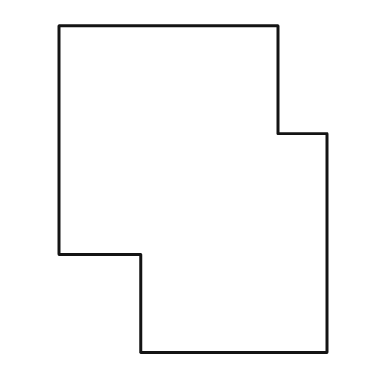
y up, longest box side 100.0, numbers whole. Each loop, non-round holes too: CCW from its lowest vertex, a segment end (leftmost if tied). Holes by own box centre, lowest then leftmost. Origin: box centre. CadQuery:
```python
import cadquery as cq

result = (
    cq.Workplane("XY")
    .moveTo(-16.0, -50.0)
    .lineTo(41.0, -50.0)
    .lineTo(41.0, 17.0)
    .lineTo(26.0, 17.0)
    .lineTo(26.0, 50.0)
    .lineTo(-41.0, 50.0)
    .lineTo(-41.0, -20.0)
    .lineTo(-16.0, -20.0)
    .close()
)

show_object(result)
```